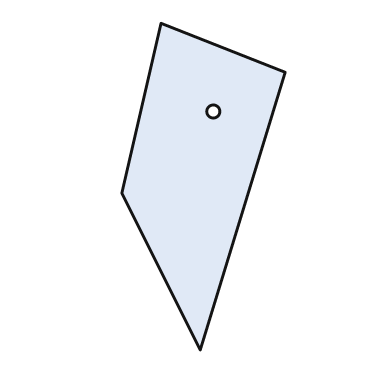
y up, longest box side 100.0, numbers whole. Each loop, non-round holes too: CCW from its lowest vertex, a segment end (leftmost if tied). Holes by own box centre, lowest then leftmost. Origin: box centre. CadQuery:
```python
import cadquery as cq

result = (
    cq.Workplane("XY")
    .moveTo(-1.0, -50.0)
    .lineTo(25.0, 35.0)
    .lineTo(-13.0, 50.0)
    .lineTo(-25.0, -2.0)
    .close()
    .moveTo(3.0, 23.0)
    .circle(2.0)
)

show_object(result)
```